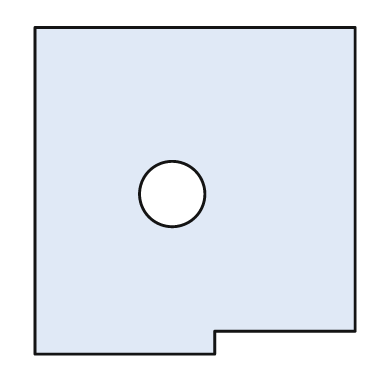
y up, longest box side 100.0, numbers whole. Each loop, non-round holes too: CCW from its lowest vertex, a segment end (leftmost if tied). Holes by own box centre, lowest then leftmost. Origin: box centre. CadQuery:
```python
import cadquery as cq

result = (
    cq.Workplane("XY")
    .moveTo(-49.0, -50.0)
    .lineTo(6.0, -50.0)
    .lineTo(6.0, -43.0)
    .lineTo(49.0, -43.0)
    .lineTo(49.0, 50.0)
    .lineTo(-49.0, 50.0)
    .close()
    .moveTo(-7.0, -1.0)
    .circle(10.0)
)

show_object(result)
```